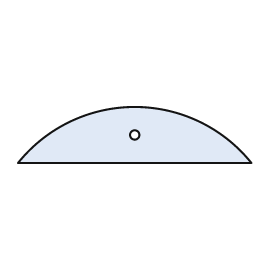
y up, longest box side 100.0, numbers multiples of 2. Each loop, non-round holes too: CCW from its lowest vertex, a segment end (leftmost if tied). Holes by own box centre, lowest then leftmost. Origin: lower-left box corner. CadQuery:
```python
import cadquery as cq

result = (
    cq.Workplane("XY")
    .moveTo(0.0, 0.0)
    .lineTo(100.0, 0.0)
    .threePointArc((50.0, 24.0), (0.0, 0.0))
    .close()
    .moveTo(50.0, 12.0)
    .circle(2.0)
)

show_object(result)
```